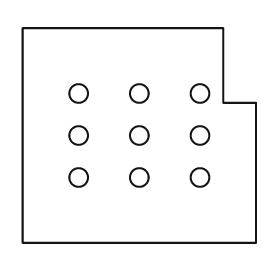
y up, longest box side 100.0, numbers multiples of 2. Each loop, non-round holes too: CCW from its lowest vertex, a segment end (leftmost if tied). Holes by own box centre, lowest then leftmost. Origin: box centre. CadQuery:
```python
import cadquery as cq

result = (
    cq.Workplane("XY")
    .moveTo(-50.0, -46.0)
    .lineTo(50.0, -46.0)
    .lineTo(50.0, 14.0)
    .lineTo(36.0, 14.0)
    .lineTo(36.0, 46.0)
    .lineTo(-50.0, 46.0)
    .close()
    .moveTo(-26.0, -18.0)
    .circle(4.0)
    .moveTo(0.0, -18.0)
    .circle(4.0)
    .moveTo(26.0, -18.0)
    .circle(4.0)
    .moveTo(-26.0, 0.0)
    .circle(4.0)
    .moveTo(0.0, 0.0)
    .circle(4.0)
    .moveTo(26.0, 0.0)
    .circle(4.0)
    .moveTo(-26.0, 18.0)
    .circle(4.0)
    .moveTo(0.0, 18.0)
    .circle(4.0)
    .moveTo(26.0, 18.0)
    .circle(4.0)
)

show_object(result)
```